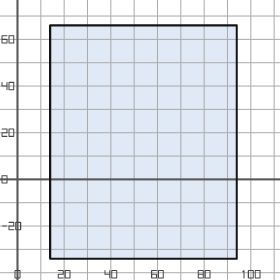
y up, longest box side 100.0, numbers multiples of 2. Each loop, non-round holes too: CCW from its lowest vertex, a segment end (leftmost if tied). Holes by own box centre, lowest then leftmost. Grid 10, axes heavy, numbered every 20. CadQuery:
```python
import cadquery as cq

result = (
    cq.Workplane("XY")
    .moveTo(14.0, -34.0)
    .lineTo(94.0, -34.0)
    .lineTo(94.0, 66.0)
    .lineTo(14.0, 66.0)
    .close()
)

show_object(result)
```